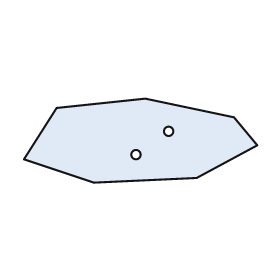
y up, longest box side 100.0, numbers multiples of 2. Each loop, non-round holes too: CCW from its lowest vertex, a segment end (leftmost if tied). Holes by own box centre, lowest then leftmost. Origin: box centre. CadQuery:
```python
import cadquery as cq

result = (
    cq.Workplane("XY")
    .moveTo(-20.0, -18.0)
    .lineTo(24.0, -16.0)
    .lineTo(50.0, -2.0)
    .lineTo(40.0, 10.0)
    .lineTo(2.0, 18.0)
    .lineTo(-36.0, 14.0)
    .lineTo(-50.0, -8.0)
    .close()
    .moveTo(-2.0, -6.0)
    .circle(2.0)
    .moveTo(12.0, 4.0)
    .circle(2.0)
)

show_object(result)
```